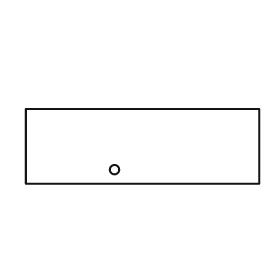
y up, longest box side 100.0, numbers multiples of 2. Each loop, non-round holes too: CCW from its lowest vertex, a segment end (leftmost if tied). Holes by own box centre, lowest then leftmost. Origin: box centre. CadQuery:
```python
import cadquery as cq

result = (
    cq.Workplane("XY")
    .moveTo(-50.0, -16.0)
    .lineTo(50.0, -16.0)
    .lineTo(50.0, 16.0)
    .lineTo(-50.0, 16.0)
    .close()
    .moveTo(-12.0, -10.0)
    .circle(2.0)
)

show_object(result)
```